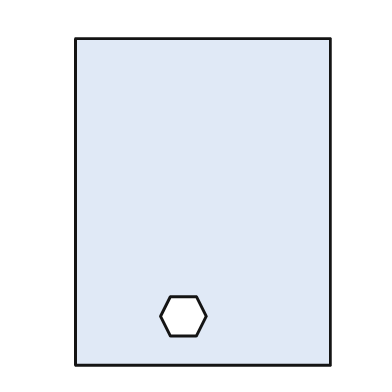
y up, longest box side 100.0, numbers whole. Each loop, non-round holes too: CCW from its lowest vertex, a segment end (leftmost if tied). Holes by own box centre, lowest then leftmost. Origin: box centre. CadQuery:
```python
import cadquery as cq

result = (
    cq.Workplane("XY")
    .moveTo(-39.0, -50.0)
    .lineTo(39.0, -50.0)
    .lineTo(39.0, 50.0)
    .lineTo(-39.0, 50.0)
    .close()
    .moveTo(-10.0, -41.0)
    .lineTo(-2.0, -41.0)
    .lineTo(1.0, -35.0)
    .lineTo(-2.0, -29.0)
    .lineTo(-10.0, -29.0)
    .lineTo(-13.0, -35.0)
    .close()
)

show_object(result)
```